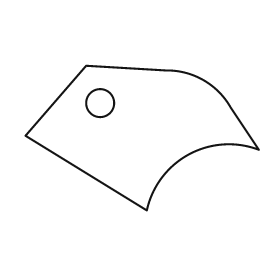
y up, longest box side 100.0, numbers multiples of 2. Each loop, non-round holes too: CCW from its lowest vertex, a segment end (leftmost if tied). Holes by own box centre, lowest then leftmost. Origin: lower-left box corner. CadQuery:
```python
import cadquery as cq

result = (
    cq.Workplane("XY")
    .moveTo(52.0, 0.0)
    .threePointArc((70.0, 24.0), (100.0, 26.0))
    .lineTo(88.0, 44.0)
    .threePointArc((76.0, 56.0), (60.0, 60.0))
    .lineTo(26.0, 62.0)
    .lineTo(0.0, 32.0)
    .close()
    .moveTo(32.0, 46.0)
    .circle(6.0)
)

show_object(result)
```